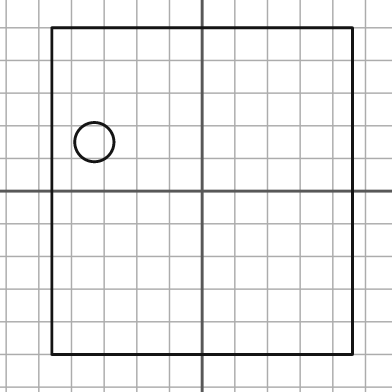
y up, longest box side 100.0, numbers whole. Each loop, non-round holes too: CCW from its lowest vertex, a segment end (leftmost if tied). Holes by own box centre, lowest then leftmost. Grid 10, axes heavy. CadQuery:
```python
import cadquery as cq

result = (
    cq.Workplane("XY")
    .moveTo(-46.0, -50.0)
    .lineTo(46.0, -50.0)
    .lineTo(46.0, 50.0)
    .lineTo(-46.0, 50.0)
    .close()
    .moveTo(-33.0, 15.0)
    .circle(6.0)
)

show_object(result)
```